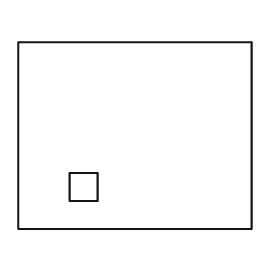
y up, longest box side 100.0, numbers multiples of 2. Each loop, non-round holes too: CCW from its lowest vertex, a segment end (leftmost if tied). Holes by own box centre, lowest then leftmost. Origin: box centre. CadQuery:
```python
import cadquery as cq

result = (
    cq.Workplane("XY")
    .moveTo(-50.0, -40.0)
    .lineTo(50.0, -40.0)
    .lineTo(50.0, 40.0)
    .lineTo(-50.0, 40.0)
    .close()
    .moveTo(-28.0, -28.0)
    .lineTo(-16.0, -28.0)
    .lineTo(-16.0, -16.0)
    .lineTo(-28.0, -16.0)
    .close()
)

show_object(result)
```